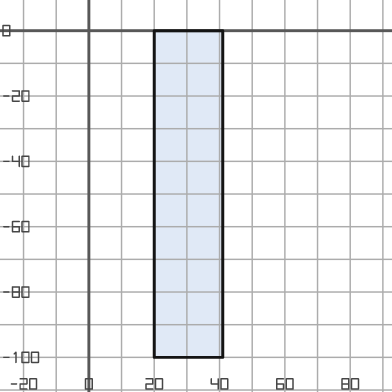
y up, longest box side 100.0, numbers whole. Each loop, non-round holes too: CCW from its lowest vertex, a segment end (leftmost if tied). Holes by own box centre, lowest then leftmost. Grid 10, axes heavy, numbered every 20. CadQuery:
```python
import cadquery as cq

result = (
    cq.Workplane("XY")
    .moveTo(20.0, -100.0)
    .lineTo(41.0, -100.0)
    .lineTo(41.0, 0.0)
    .lineTo(20.0, 0.0)
    .close()
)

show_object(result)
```